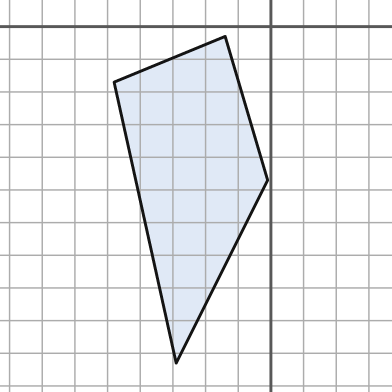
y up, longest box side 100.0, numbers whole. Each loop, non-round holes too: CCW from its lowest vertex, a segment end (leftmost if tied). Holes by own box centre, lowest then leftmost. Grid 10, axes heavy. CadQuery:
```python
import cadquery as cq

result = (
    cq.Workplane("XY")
    .moveTo(-29.0, -103.0)
    .lineTo(-1.0, -47.0)
    .lineTo(-14.0, -3.0)
    .lineTo(-48.0, -17.0)
    .close()
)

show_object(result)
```